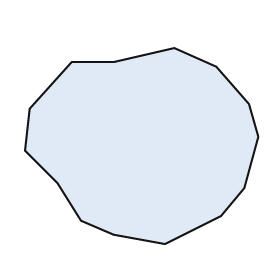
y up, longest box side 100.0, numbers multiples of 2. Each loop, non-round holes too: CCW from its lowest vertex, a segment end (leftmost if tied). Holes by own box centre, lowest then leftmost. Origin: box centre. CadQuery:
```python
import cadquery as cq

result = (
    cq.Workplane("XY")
    .moveTo(10.0, -42.0)
    .lineTo(34.0, -30.0)
    .lineTo(44.0, -18.0)
    .lineTo(50.0, 4.0)
    .lineTo(46.0, 18.0)
    .lineTo(32.0, 34.0)
    .lineTo(14.0, 42.0)
    .lineTo(-12.0, 36.0)
    .lineTo(-30.0, 36.0)
    .lineTo(-48.0, 16.0)
    .lineTo(-50.0, -2.0)
    .lineTo(-36.0, -16.0)
    .lineTo(-26.0, -32.0)
    .lineTo(-12.0, -38.0)
    .close()
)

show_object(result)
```